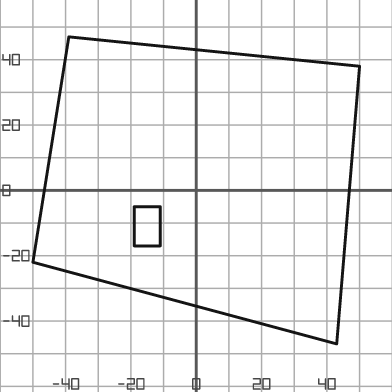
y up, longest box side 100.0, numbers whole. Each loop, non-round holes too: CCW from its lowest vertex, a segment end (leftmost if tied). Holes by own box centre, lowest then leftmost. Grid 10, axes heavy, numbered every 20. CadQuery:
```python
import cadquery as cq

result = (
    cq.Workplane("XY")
    .moveTo(43.0, -47.0)
    .lineTo(50.0, 38.0)
    .lineTo(-39.0, 47.0)
    .lineTo(-50.0, -22.0)
    .close()
    .moveTo(-19.0, -17.0)
    .lineTo(-11.0, -17.0)
    .lineTo(-11.0, -5.0)
    .lineTo(-19.0, -5.0)
    .close()
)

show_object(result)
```